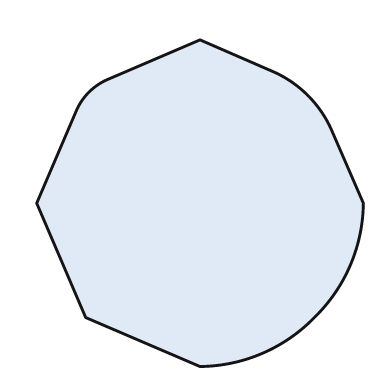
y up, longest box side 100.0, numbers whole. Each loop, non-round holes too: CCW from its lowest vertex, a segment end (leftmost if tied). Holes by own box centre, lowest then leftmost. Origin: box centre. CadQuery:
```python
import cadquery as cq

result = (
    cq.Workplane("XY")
    .moveTo(0.0, -50.0)
    .threePointArc((19.0, -46.0), (35.0, -35.0))
    .threePointArc((46.0, -19.0), (50.0, 0.0))
    .lineTo(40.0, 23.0)
    .threePointArc((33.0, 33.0), (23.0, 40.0))
    .lineTo(0.0, 50.0)
    .lineTo(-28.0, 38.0)
    .threePointArc((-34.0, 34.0), (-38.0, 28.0))
    .lineTo(-50.0, 0.0)
    .lineTo(-35.0, -35.0)
    .close()
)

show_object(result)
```